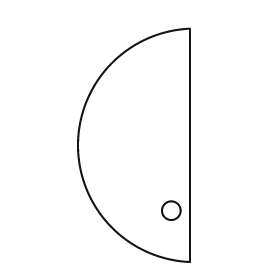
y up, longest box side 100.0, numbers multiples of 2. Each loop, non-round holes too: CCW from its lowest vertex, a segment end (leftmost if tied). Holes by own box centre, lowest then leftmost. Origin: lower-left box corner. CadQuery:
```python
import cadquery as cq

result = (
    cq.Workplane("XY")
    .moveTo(48.0, 0.0)
    .lineTo(48.0, 100.0)
    .threePointArc((0.0, 50.0), (48.0, 0.0))
    .close()
    .moveTo(40.0, 22.0)
    .circle(4.0)
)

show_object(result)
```